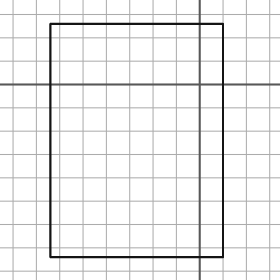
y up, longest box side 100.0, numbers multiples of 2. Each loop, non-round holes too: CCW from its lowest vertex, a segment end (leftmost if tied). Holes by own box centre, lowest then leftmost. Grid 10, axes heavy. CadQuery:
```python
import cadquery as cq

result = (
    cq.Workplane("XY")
    .moveTo(-64.0, -74.0)
    .lineTo(10.0, -74.0)
    .lineTo(10.0, 26.0)
    .lineTo(-64.0, 26.0)
    .close()
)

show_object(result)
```